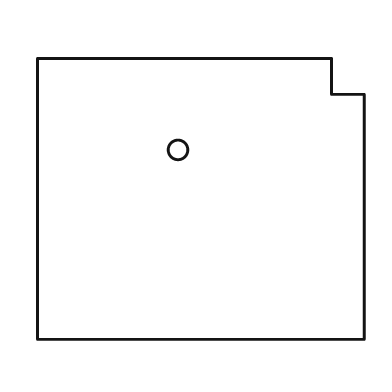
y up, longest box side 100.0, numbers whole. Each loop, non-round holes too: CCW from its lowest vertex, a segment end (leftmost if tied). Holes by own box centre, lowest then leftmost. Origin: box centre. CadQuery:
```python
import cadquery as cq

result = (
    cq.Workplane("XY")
    .moveTo(-50.0, -43.0)
    .lineTo(50.0, -43.0)
    .lineTo(50.0, 32.0)
    .lineTo(40.0, 32.0)
    .lineTo(40.0, 43.0)
    .lineTo(-50.0, 43.0)
    .close()
    .moveTo(-7.0, 15.0)
    .circle(3.0)
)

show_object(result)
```